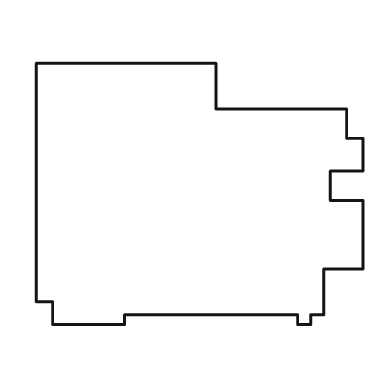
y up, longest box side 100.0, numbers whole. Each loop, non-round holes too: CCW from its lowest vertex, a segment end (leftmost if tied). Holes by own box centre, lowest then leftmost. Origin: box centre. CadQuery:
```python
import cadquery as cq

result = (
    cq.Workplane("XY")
    .moveTo(-45.0, -40.0)
    .lineTo(-23.0, -40.0)
    .lineTo(-23.0, -37.0)
    .lineTo(30.0, -37.0)
    .lineTo(30.0, -40.0)
    .lineTo(34.0, -40.0)
    .lineTo(34.0, -37.0)
    .lineTo(38.0, -37.0)
    .lineTo(38.0, -23.0)
    .lineTo(50.0, -23.0)
    .lineTo(50.0, -2.0)
    .lineTo(40.0, -2.0)
    .lineTo(40.0, 7.0)
    .lineTo(50.0, 7.0)
    .lineTo(50.0, 17.0)
    .lineTo(45.0, 17.0)
    .lineTo(45.0, 26.0)
    .lineTo(5.0, 26.0)
    .lineTo(5.0, 40.0)
    .lineTo(-50.0, 40.0)
    .lineTo(-50.0, -33.0)
    .lineTo(-45.0, -33.0)
    .close()
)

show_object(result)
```